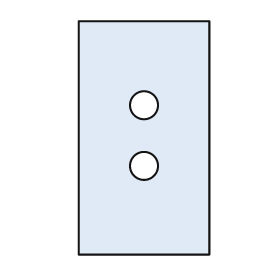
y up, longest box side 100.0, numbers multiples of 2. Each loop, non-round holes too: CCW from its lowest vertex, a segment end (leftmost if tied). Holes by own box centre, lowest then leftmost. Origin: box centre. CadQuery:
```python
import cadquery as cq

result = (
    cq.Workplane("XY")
    .moveTo(-28.0, -50.0)
    .lineTo(28.0, -50.0)
    .lineTo(28.0, 50.0)
    .lineTo(-28.0, 50.0)
    .close()
    .moveTo(0.0, -12.0)
    .circle(6.0)
    .moveTo(0.0, 14.0)
    .circle(6.0)
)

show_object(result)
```